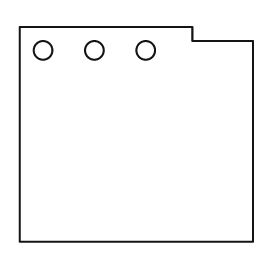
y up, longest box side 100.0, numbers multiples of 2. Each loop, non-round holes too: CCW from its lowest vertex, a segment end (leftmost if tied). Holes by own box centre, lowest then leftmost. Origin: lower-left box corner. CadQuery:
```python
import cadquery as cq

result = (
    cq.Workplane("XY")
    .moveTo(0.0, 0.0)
    .lineTo(100.0, 0.0)
    .lineTo(100.0, 86.0)
    .lineTo(74.0, 86.0)
    .lineTo(74.0, 92.0)
    .lineTo(0.0, 92.0)
    .close()
    .moveTo(10.0, 82.0)
    .circle(4.0)
    .moveTo(32.0, 82.0)
    .circle(4.0)
    .moveTo(54.0, 82.0)
    .circle(4.0)
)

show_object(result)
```